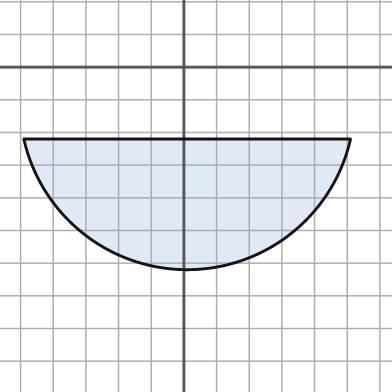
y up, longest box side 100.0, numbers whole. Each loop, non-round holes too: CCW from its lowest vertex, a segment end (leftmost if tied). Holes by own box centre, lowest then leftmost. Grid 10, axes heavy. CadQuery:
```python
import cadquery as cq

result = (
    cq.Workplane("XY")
    .moveTo(-49.0, -22.0)
    .threePointArc((1.0, -62.0), (51.0, -22.0))
    .close()
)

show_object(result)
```